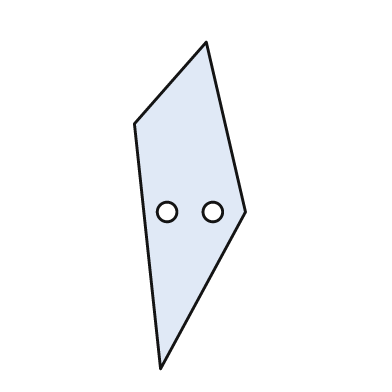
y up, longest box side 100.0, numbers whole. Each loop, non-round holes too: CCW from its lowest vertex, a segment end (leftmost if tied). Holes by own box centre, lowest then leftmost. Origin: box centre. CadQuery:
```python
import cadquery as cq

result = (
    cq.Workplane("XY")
    .moveTo(-9.0, -50.0)
    .lineTo(17.0, -2.0)
    .lineTo(5.0, 50.0)
    .lineTo(-17.0, 25.0)
    .close()
    .moveTo(-7.0, -2.0)
    .circle(3.0)
    .moveTo(7.0, -2.0)
    .circle(3.0)
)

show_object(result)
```